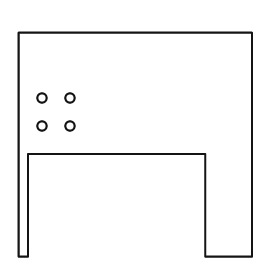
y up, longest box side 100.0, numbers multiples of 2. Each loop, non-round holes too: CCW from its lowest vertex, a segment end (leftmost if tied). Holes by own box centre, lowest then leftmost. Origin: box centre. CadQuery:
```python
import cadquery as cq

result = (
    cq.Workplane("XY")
    .moveTo(-50.0, -48.0)
    .lineTo(-46.0, -48.0)
    .lineTo(-46.0, -4.0)
    .lineTo(30.0, -4.0)
    .lineTo(30.0, -48.0)
    .lineTo(50.0, -48.0)
    .lineTo(50.0, 48.0)
    .lineTo(-50.0, 48.0)
    .close()
    .moveTo(-40.0, 8.0)
    .circle(2.0)
    .moveTo(-28.0, 8.0)
    .circle(2.0)
    .moveTo(-40.0, 20.0)
    .circle(2.0)
    .moveTo(-28.0, 20.0)
    .circle(2.0)
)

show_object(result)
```